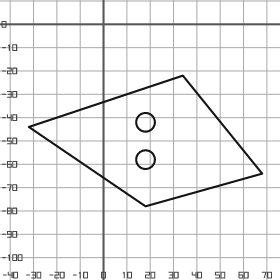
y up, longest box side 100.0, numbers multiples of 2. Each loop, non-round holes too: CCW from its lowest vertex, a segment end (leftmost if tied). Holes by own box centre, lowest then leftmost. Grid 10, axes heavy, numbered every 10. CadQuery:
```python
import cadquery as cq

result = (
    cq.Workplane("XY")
    .moveTo(18.0, -78.0)
    .lineTo(68.0, -64.0)
    .lineTo(34.0, -22.0)
    .lineTo(-32.0, -44.0)
    .close()
    .moveTo(18.0, -58.0)
    .circle(4.0)
    .moveTo(18.0, -42.0)
    .circle(4.0)
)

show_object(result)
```